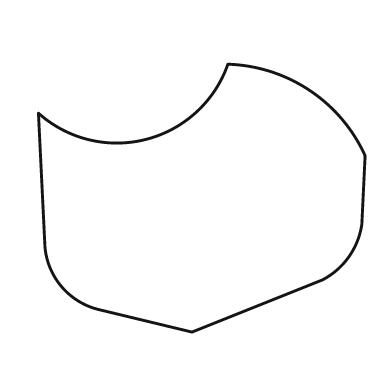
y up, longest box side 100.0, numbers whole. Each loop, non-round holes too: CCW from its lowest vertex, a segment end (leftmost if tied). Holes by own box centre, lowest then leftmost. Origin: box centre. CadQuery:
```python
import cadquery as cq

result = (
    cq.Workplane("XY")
    .moveTo(-3.0, -41.0)
    .lineTo(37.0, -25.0)
    .threePointArc((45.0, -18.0), (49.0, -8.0))
    .lineTo(50.0, 13.0)
    .threePointArc((33.0, 33.0), (8.0, 41.0))
    .threePointArc((-17.0, 18.0), (-50.0, 26.0))
    .lineTo(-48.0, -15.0)
    .threePointArc((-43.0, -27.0), (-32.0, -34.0))
    .close()
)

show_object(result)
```